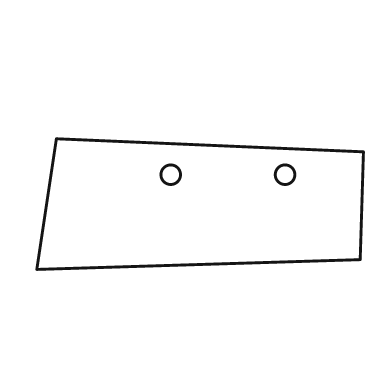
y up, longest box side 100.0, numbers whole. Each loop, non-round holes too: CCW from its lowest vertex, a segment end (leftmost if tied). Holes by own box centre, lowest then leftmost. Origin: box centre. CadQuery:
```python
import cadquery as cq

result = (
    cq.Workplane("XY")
    .moveTo(-50.0, -20.0)
    .lineTo(49.0, -17.0)
    .lineTo(50.0, 16.0)
    .lineTo(-44.0, 20.0)
    .close()
    .moveTo(-9.0, 9.0)
    .circle(3.0)
    .moveTo(26.0, 9.0)
    .circle(3.0)
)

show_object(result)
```